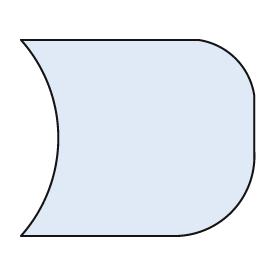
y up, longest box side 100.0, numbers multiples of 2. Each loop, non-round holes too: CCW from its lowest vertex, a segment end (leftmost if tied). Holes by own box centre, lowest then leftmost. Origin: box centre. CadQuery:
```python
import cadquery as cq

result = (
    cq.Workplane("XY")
    .moveTo(-50.0, -42.0)
    .lineTo(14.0, -42.0)
    .threePointArc((40.0, -32.0), (50.0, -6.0))
    .lineTo(50.0, 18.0)
    .threePointArc((42.0, 34.0), (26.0, 42.0))
    .lineTo(-50.0, 42.0)
    .threePointArc((-34.0, 0.0), (-50.0, -42.0))
    .close()
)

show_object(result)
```